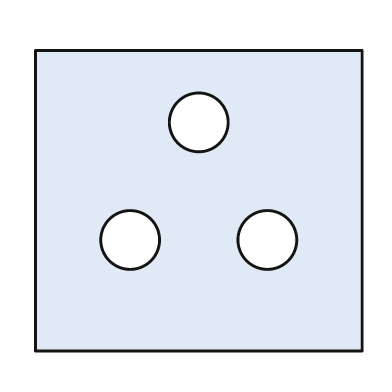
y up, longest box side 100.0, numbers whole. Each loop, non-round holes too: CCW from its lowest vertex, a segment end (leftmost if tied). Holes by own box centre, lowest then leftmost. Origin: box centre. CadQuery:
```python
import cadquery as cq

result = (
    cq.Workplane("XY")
    .moveTo(-50.0, -46.0)
    .lineTo(50.0, -46.0)
    .lineTo(50.0, 46.0)
    .lineTo(-50.0, 46.0)
    .close()
    .moveTo(-21.0, -12.0)
    .circle(9.0)
    .moveTo(21.0, -12.0)
    .circle(9.0)
    .moveTo(0.0, 24.0)
    .circle(9.0)
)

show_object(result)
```